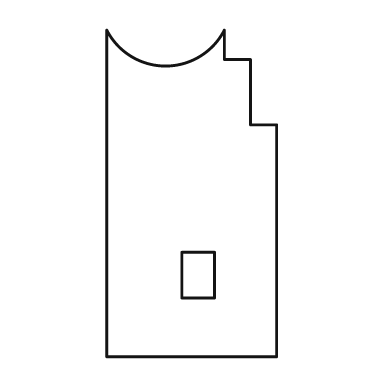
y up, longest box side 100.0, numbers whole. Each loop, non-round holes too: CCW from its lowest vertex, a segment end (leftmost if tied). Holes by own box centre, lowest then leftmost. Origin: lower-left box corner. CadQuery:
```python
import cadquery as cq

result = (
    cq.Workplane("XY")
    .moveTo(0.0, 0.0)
    .lineTo(52.0, 0.0)
    .lineTo(52.0, 71.0)
    .lineTo(44.0, 71.0)
    .lineTo(44.0, 91.0)
    .lineTo(36.0, 91.0)
    .lineTo(36.0, 100.0)
    .threePointArc((18.0, 89.0), (0.0, 100.0))
    .close()
    .moveTo(23.0, 18.0)
    .lineTo(33.0, 18.0)
    .lineTo(33.0, 32.0)
    .lineTo(23.0, 32.0)
    .close()
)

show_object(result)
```